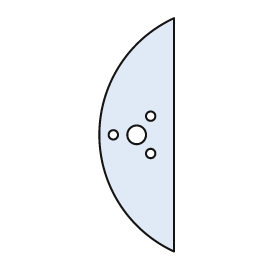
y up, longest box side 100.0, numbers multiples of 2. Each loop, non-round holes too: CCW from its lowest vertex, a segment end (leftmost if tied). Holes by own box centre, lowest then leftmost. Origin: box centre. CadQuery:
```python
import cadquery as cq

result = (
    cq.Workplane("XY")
    .moveTo(16.0, -50.0)
    .lineTo(16.0, 50.0)
    .threePointArc((-16.0, 0.0), (16.0, -50.0))
    .close()
    .moveTo(6.0, -8.0)
    .circle(2.0)
    .moveTo(-10.0, 0.0)
    .circle(2.0)
    .moveTo(0.0, 0.0)
    .circle(4.0)
    .moveTo(6.0, 8.0)
    .circle(2.0)
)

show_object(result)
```